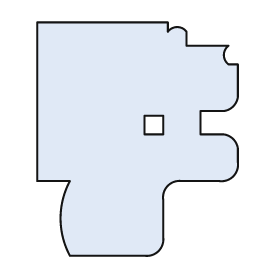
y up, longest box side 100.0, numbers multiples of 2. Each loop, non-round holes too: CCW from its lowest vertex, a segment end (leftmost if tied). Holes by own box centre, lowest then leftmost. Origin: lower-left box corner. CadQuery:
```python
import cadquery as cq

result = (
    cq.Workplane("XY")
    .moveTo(14.0, 0.0)
    .lineTo(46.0, 0.0)
    .threePointArc((52.0, 2.0), (54.0, 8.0))
    .lineTo(54.0, 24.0)
    .threePointArc((56.0, 30.0), (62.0, 32.0))
    .lineTo(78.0, 32.0)
    .threePointArc((84.0, 34.0), (86.0, 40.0))
    .lineTo(86.0, 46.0)
    .threePointArc((84.0, 50.0), (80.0, 52.0))
    .lineTo(70.0, 52.0)
    .lineTo(70.0, 62.0)
    .lineTo(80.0, 62.0)
    .threePointArc((84.0, 64.0), (86.0, 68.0))
    .lineTo(86.0, 82.0)
    .lineTo(82.0, 82.0)
    .threePointArc((80.0, 86.0), (82.0, 90.0))
    .lineTo(64.0, 90.0)
    .lineTo(64.0, 96.0)
    .threePointArc((60.0, 98.0), (56.0, 96.0))
    .lineTo(56.0, 100.0)
    .lineTo(0.0, 100.0)
    .lineTo(0.0, 32.0)
    .lineTo(14.0, 32.0)
    .threePointArc((10.0, 16.0), (14.0, 0.0))
    .close()
    .moveTo(46.0, 52.0)
    .lineTo(54.0, 52.0)
    .lineTo(54.0, 60.0)
    .lineTo(46.0, 60.0)
    .close()
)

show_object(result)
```